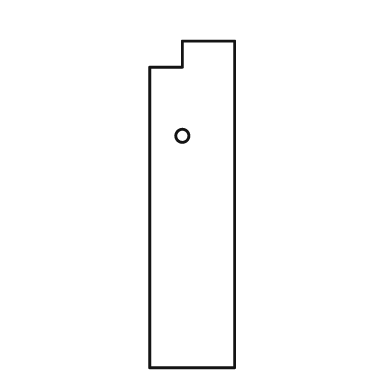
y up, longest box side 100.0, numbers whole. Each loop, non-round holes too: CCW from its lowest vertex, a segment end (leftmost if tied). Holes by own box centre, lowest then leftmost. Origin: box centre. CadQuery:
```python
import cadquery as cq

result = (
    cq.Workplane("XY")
    .moveTo(-13.0, -50.0)
    .lineTo(13.0, -50.0)
    .lineTo(13.0, 50.0)
    .lineTo(-3.0, 50.0)
    .lineTo(-3.0, 42.0)
    .lineTo(-13.0, 42.0)
    .close()
    .moveTo(-3.0, 21.0)
    .circle(2.0)
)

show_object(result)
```